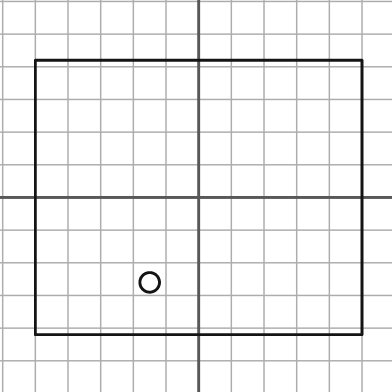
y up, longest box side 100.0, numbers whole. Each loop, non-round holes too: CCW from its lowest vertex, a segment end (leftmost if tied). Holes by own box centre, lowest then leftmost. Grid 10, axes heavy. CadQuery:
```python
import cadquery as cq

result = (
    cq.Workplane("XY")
    .moveTo(-50.0, -42.0)
    .lineTo(50.0, -42.0)
    .lineTo(50.0, 42.0)
    .lineTo(-50.0, 42.0)
    .close()
    .moveTo(-15.0, -26.0)
    .circle(3.0)
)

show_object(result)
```